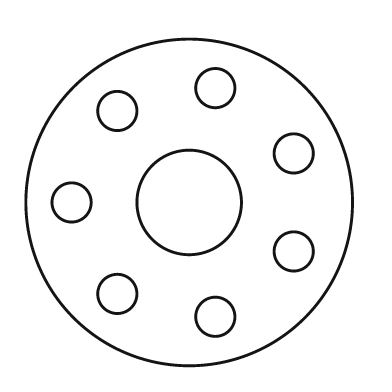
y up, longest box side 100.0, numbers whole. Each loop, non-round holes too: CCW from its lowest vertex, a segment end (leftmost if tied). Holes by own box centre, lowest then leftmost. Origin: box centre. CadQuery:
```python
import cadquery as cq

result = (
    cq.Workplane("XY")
    .moveTo(0.0, 0.0)
    .circle(50.0)
    .moveTo(8.0, -35.0)
    .circle(6.0)
    .moveTo(-22.0, -28.0)
    .circle(6.0)
    .moveTo(32.0, -15.0)
    .circle(6.0)
    .moveTo(-36.0, 0.0)
    .circle(6.0)
    .moveTo(0.0, 0.0)
    .circle(16.0)
    .moveTo(32.0, 15.0)
    .circle(6.0)
    .moveTo(-22.0, 28.0)
    .circle(6.0)
    .moveTo(8.0, 35.0)
    .circle(6.0)
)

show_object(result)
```